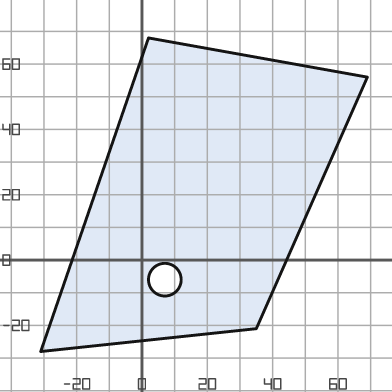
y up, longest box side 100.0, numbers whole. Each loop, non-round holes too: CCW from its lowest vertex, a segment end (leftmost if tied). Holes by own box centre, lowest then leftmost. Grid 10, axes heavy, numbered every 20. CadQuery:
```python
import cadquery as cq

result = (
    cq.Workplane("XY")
    .moveTo(-31.0, -28.0)
    .lineTo(35.0, -21.0)
    .lineTo(69.0, 56.0)
    .lineTo(2.0, 68.0)
    .close()
    .moveTo(7.0, -6.0)
    .circle(5.0)
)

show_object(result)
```